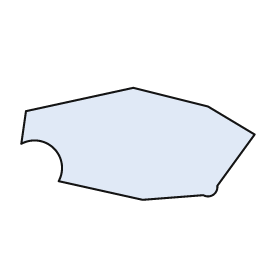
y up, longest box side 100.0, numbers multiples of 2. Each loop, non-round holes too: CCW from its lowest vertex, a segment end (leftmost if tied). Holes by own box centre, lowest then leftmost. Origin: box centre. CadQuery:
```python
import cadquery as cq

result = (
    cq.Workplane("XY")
    .moveTo(2.0, -24.0)
    .lineTo(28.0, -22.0)
    .threePointArc((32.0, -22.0), (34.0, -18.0))
    .lineTo(50.0, 4.0)
    .lineTo(30.0, 16.0)
    .lineTo(-2.0, 24.0)
    .lineTo(-48.0, 14.0)
    .lineTo(-50.0, 0.0)
    .threePointArc((-36.0, -2.0), (-34.0, -16.0))
    .close()
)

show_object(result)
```